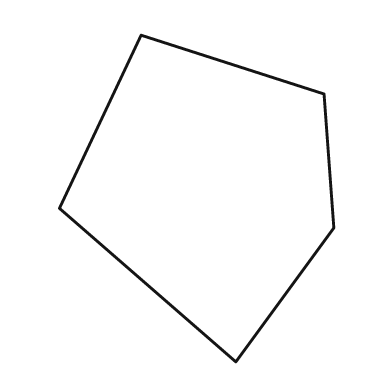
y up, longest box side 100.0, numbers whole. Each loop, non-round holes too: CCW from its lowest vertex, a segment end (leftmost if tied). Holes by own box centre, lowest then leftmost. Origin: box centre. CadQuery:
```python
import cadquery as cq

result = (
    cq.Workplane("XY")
    .moveTo(12.0, -50.0)
    .lineTo(42.0, -9.0)
    .lineTo(39.0, 32.0)
    .lineTo(-17.0, 50.0)
    .lineTo(-42.0, -3.0)
    .close()
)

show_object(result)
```